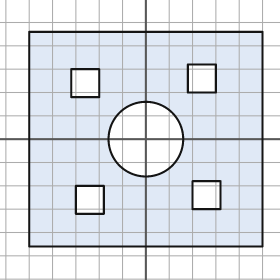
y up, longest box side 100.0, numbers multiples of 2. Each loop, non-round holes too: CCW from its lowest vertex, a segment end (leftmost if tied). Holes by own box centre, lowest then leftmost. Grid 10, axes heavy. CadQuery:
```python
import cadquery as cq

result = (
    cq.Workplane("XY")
    .moveTo(-50.0, -46.0)
    .lineTo(50.0, -46.0)
    .lineTo(50.0, 46.0)
    .lineTo(-50.0, 46.0)
    .close()
    .moveTo(-30.0, -32.0)
    .lineTo(-18.0, -32.0)
    .lineTo(-18.0, -20.0)
    .lineTo(-30.0, -20.0)
    .close()
    .moveTo(20.0, -30.0)
    .lineTo(32.0, -30.0)
    .lineTo(32.0, -18.0)
    .lineTo(20.0, -18.0)
    .close()
    .moveTo(0.0, 0.0)
    .circle(16.0)
    .moveTo(-32.0, 18.0)
    .lineTo(-20.0, 18.0)
    .lineTo(-20.0, 30.0)
    .lineTo(-32.0, 30.0)
    .close()
    .moveTo(18.0, 20.0)
    .lineTo(30.0, 20.0)
    .lineTo(30.0, 32.0)
    .lineTo(18.0, 32.0)
    .close()
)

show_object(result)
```